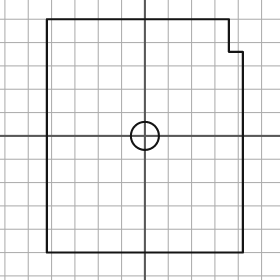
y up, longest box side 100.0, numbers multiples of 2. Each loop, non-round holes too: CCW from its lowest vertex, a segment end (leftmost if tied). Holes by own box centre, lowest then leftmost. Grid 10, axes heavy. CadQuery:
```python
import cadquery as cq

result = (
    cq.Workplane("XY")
    .moveTo(-42.0, -50.0)
    .lineTo(42.0, -50.0)
    .lineTo(42.0, 36.0)
    .lineTo(36.0, 36.0)
    .lineTo(36.0, 50.0)
    .lineTo(-42.0, 50.0)
    .close()
    .moveTo(0.0, 0.0)
    .circle(6.0)
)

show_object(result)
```